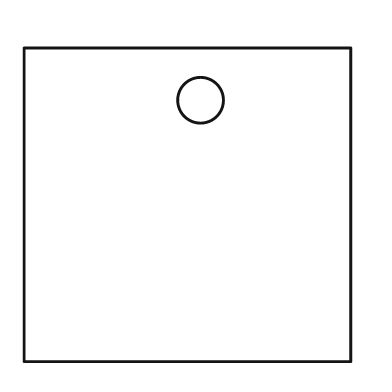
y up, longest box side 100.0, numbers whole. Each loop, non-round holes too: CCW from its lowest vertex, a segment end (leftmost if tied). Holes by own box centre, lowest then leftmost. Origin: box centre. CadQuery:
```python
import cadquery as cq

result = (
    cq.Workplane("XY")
    .moveTo(-50.0, -48.0)
    .lineTo(50.0, -48.0)
    .lineTo(50.0, 48.0)
    .lineTo(-50.0, 48.0)
    .close()
    .moveTo(4.0, 32.0)
    .circle(7.0)
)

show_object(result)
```